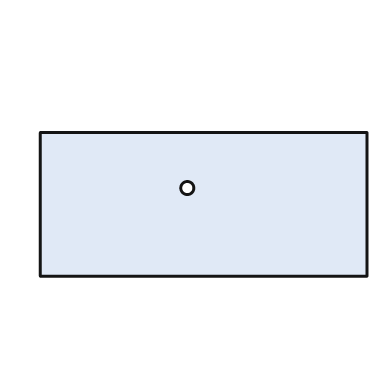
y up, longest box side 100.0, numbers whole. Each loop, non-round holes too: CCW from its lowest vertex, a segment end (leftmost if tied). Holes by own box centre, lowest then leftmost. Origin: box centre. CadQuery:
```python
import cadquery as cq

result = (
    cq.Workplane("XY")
    .moveTo(-50.0, -22.0)
    .lineTo(50.0, -22.0)
    .lineTo(50.0, 22.0)
    .lineTo(-50.0, 22.0)
    .close()
    .moveTo(-5.0, 5.0)
    .circle(2.0)
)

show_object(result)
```